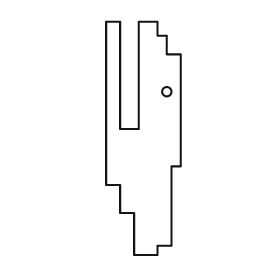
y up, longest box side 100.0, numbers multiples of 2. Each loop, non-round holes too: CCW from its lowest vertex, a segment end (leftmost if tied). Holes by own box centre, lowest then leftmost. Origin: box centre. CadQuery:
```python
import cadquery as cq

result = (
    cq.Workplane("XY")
    .moveTo(-4.0, -50.0)
    .lineTo(6.0, -50.0)
    .lineTo(6.0, -46.0)
    .lineTo(12.0, -46.0)
    .lineTo(12.0, -12.0)
    .lineTo(16.0, -12.0)
    .lineTo(16.0, 36.0)
    .lineTo(10.0, 36.0)
    .lineTo(10.0, 44.0)
    .lineTo(6.0, 44.0)
    .lineTo(6.0, 50.0)
    .lineTo(-2.0, 50.0)
    .lineTo(-2.0, 4.0)
    .lineTo(-10.0, 4.0)
    .lineTo(-10.0, 50.0)
    .lineTo(-16.0, 50.0)
    .lineTo(-16.0, -20.0)
    .lineTo(-10.0, -20.0)
    .lineTo(-10.0, -32.0)
    .lineTo(-4.0, -32.0)
    .close()
    .moveTo(10.0, 20.0)
    .circle(2.0)
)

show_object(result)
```